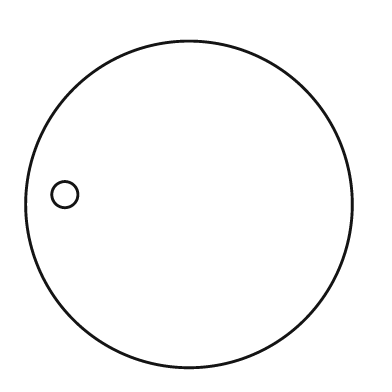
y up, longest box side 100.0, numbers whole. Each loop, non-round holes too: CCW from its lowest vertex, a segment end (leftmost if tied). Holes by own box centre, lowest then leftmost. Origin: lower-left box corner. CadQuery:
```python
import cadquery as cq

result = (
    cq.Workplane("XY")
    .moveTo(50.0, 50.0)
    .circle(50.0)
    .moveTo(12.0, 53.0)
    .circle(4.0)
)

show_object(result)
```